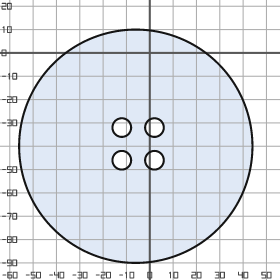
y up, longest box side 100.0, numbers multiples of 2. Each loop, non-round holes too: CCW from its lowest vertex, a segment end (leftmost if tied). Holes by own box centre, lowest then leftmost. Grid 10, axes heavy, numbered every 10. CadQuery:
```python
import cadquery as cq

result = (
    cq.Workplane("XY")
    .moveTo(-6.0, -40.0)
    .circle(50.0)
    .moveTo(-12.0, -46.0)
    .circle(4.0)
    .moveTo(2.0, -46.0)
    .circle(4.0)
    .moveTo(-12.0, -32.0)
    .circle(4.0)
    .moveTo(2.0, -32.0)
    .circle(4.0)
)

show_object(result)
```